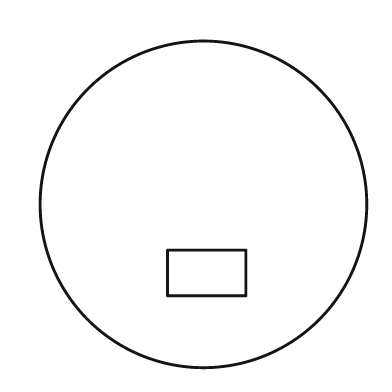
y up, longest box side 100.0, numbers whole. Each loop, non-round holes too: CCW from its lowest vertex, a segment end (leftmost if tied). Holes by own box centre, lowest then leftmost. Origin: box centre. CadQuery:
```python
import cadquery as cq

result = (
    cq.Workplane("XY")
    .moveTo(0.0, 0.0)
    .circle(50.0)
    .moveTo(-11.0, -28.0)
    .lineTo(13.0, -28.0)
    .lineTo(13.0, -14.0)
    .lineTo(-11.0, -14.0)
    .close()
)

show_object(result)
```